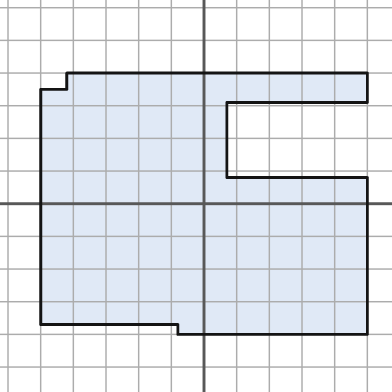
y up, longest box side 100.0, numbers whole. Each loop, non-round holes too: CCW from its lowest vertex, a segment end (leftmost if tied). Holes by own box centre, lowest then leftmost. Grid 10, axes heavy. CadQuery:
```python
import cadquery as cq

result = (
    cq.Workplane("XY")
    .moveTo(-8.0, -40.0)
    .lineTo(50.0, -40.0)
    .lineTo(50.0, 8.0)
    .lineTo(7.0, 8.0)
    .lineTo(7.0, 31.0)
    .lineTo(50.0, 31.0)
    .lineTo(50.0, 40.0)
    .lineTo(-42.0, 40.0)
    .lineTo(-42.0, 35.0)
    .lineTo(-50.0, 35.0)
    .lineTo(-50.0, -37.0)
    .lineTo(-8.0, -37.0)
    .close()
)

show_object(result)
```